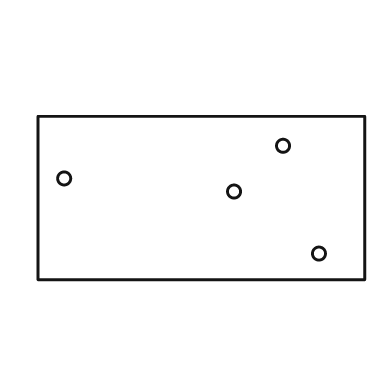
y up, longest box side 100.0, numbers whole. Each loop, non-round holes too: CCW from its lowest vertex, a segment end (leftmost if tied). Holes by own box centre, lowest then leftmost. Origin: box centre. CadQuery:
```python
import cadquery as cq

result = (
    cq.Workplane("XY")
    .moveTo(-50.0, -25.0)
    .lineTo(50.0, -25.0)
    .lineTo(50.0, 25.0)
    .lineTo(-50.0, 25.0)
    .close()
    .moveTo(36.0, -17.0)
    .circle(2.0)
    .moveTo(10.0, 2.0)
    .circle(2.0)
    .moveTo(-42.0, 6.0)
    .circle(2.0)
    .moveTo(25.0, 16.0)
    .circle(2.0)
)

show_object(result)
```